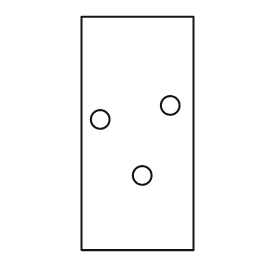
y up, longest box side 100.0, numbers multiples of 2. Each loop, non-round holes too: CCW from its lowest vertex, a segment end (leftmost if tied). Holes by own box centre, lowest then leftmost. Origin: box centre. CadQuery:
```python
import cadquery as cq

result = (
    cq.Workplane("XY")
    .moveTo(-24.0, -50.0)
    .lineTo(24.0, -50.0)
    .lineTo(24.0, 50.0)
    .lineTo(-24.0, 50.0)
    .close()
    .moveTo(2.0, -18.0)
    .circle(4.0)
    .moveTo(-16.0, 6.0)
    .circle(4.0)
    .moveTo(14.0, 12.0)
    .circle(4.0)
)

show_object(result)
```